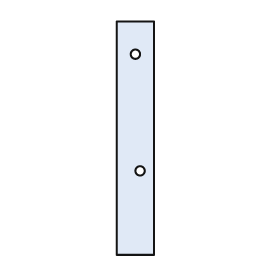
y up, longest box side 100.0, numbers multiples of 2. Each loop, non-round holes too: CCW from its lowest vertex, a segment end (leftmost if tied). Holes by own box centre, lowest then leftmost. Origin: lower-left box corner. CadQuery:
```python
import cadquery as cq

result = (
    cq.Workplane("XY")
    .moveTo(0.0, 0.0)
    .lineTo(16.0, 0.0)
    .lineTo(16.0, 100.0)
    .lineTo(0.0, 100.0)
    .close()
    .moveTo(10.0, 36.0)
    .circle(2.0)
    .moveTo(8.0, 86.0)
    .circle(2.0)
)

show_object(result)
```